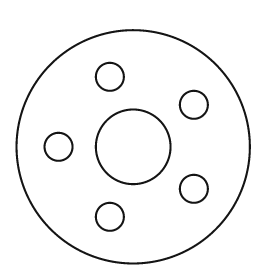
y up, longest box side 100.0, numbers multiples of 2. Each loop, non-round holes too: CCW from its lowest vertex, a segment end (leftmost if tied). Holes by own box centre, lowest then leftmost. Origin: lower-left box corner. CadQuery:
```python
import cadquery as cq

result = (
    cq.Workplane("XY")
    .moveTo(50.0, 50.0)
    .circle(50.0)
    .moveTo(40.0, 20.0)
    .circle(6.0)
    .moveTo(76.0, 32.0)
    .circle(6.0)
    .moveTo(18.0, 50.0)
    .circle(6.0)
    .moveTo(50.0, 50.0)
    .circle(16.0)
    .moveTo(76.0, 68.0)
    .circle(6.0)
    .moveTo(40.0, 80.0)
    .circle(6.0)
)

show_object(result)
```